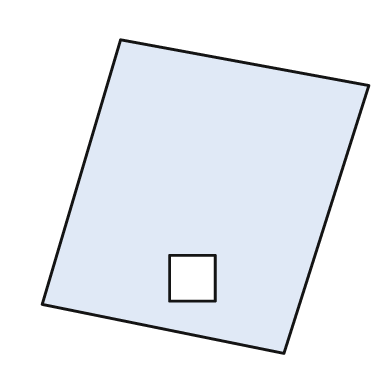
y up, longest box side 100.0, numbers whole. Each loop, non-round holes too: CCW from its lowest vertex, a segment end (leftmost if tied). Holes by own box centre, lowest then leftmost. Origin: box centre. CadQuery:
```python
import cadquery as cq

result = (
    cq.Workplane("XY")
    .moveTo(24.0, -48.0)
    .lineTo(50.0, 34.0)
    .lineTo(-26.0, 48.0)
    .lineTo(-50.0, -33.0)
    .close()
    .moveTo(-11.0, -32.0)
    .lineTo(3.0, -32.0)
    .lineTo(3.0, -18.0)
    .lineTo(-11.0, -18.0)
    .close()
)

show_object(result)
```